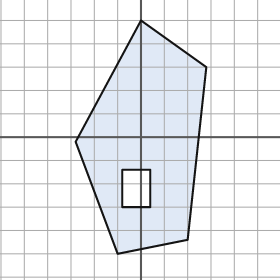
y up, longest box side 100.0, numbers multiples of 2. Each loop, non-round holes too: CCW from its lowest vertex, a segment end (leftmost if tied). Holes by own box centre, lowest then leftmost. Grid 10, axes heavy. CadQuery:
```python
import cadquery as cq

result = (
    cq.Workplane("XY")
    .moveTo(-10.0, -50.0)
    .lineTo(20.0, -44.0)
    .lineTo(28.0, 30.0)
    .lineTo(0.0, 50.0)
    .lineTo(-28.0, -2.0)
    .close()
    .moveTo(-8.0, -30.0)
    .lineTo(4.0, -30.0)
    .lineTo(4.0, -14.0)
    .lineTo(-8.0, -14.0)
    .close()
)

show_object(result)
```